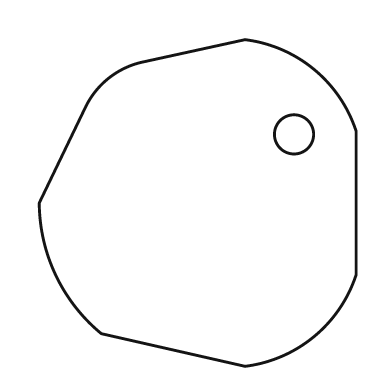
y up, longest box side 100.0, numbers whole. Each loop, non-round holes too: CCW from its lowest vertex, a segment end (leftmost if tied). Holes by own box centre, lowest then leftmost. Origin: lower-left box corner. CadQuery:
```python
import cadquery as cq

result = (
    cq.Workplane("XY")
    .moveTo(63.0, 0.0)
    .threePointArc((84.0, 9.0), (97.0, 28.0))
    .lineTo(97.0, 72.0)
    .threePointArc((84.0, 91.0), (63.0, 100.0))
    .lineTo(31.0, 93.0)
    .threePointArc((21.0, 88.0), (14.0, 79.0))
    .lineTo(0.0, 50.0)
    .threePointArc((5.0, 28.0), (19.0, 10.0))
    .close()
    .moveTo(78.0, 71.0)
    .circle(6.0)
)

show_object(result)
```